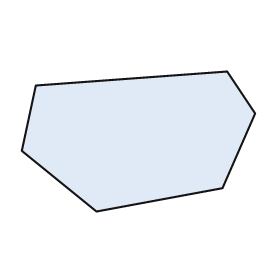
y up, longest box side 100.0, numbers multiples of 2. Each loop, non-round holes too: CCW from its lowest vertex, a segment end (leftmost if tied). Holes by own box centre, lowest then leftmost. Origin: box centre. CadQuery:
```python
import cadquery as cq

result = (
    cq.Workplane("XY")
    .moveTo(-18.0, -30.0)
    .lineTo(36.0, -20.0)
    .lineTo(50.0, 12.0)
    .lineTo(38.0, 30.0)
    .lineTo(-44.0, 24.0)
    .lineTo(-50.0, -4.0)
    .close()
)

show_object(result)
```